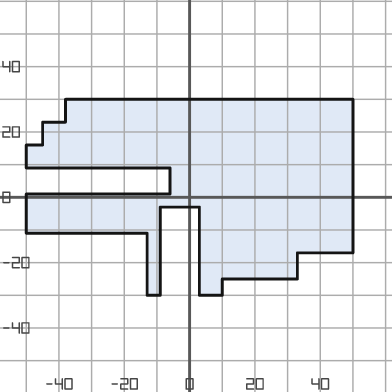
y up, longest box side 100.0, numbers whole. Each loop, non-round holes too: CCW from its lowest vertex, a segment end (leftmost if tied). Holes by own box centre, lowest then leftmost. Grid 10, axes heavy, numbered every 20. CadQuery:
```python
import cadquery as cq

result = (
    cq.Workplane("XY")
    .moveTo(-13.0, -30.0)
    .lineTo(-9.0, -30.0)
    .lineTo(-9.0, -3.0)
    .lineTo(3.0, -3.0)
    .lineTo(3.0, -30.0)
    .lineTo(10.0, -30.0)
    .lineTo(10.0, -25.0)
    .lineTo(33.0, -25.0)
    .lineTo(33.0, -17.0)
    .lineTo(50.0, -17.0)
    .lineTo(50.0, 30.0)
    .lineTo(-38.0, 30.0)
    .lineTo(-38.0, 23.0)
    .lineTo(-45.0, 23.0)
    .lineTo(-45.0, 16.0)
    .lineTo(-50.0, 16.0)
    .lineTo(-50.0, 9.0)
    .lineTo(-6.0, 9.0)
    .lineTo(-6.0, 1.0)
    .lineTo(-50.0, 1.0)
    .lineTo(-50.0, -11.0)
    .lineTo(-13.0, -11.0)
    .close()
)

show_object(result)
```